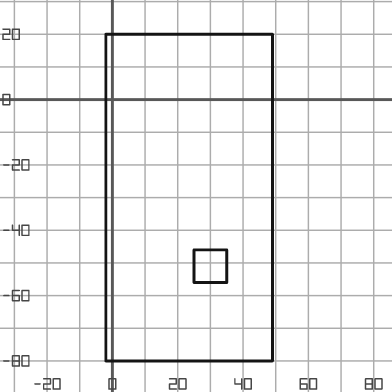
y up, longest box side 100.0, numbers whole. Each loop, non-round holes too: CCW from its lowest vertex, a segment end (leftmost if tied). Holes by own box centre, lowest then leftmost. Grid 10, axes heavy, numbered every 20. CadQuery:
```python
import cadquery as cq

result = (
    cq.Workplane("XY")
    .moveTo(-2.0, -80.0)
    .lineTo(49.0, -80.0)
    .lineTo(49.0, 20.0)
    .lineTo(-2.0, 20.0)
    .close()
    .moveTo(25.0, -56.0)
    .lineTo(35.0, -56.0)
    .lineTo(35.0, -46.0)
    .lineTo(25.0, -46.0)
    .close()
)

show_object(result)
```